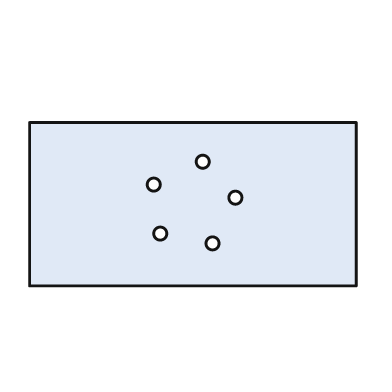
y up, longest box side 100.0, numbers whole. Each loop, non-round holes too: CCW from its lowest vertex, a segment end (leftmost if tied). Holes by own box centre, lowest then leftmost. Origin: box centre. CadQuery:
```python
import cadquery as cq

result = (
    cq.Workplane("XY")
    .moveTo(-50.0, -25.0)
    .lineTo(50.0, -25.0)
    .lineTo(50.0, 25.0)
    .lineTo(-50.0, 25.0)
    .close()
    .moveTo(6.0, -12.0)
    .circle(2.0)
    .moveTo(-10.0, -9.0)
    .circle(2.0)
    .moveTo(13.0, 2.0)
    .circle(2.0)
    .moveTo(-12.0, 6.0)
    .circle(2.0)
    .moveTo(3.0, 13.0)
    .circle(2.0)
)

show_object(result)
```